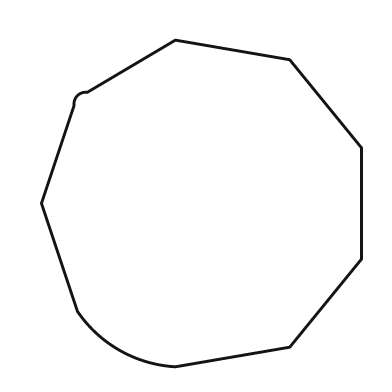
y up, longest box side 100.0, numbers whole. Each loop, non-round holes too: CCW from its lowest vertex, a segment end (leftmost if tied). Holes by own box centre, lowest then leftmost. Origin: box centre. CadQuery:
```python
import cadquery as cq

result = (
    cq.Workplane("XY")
    .moveTo(-8.0, -50.0)
    .lineTo(27.0, -44.0)
    .lineTo(49.0, -17.0)
    .lineTo(49.0, 17.0)
    .lineTo(27.0, 44.0)
    .lineTo(-8.0, 50.0)
    .lineTo(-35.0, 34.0)
    .threePointArc((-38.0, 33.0), (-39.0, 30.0))
    .lineTo(-49.0, 0.0)
    .lineTo(-38.0, -33.0)
    .threePointArc((-25.0, -45.0), (-8.0, -50.0))
    .close()
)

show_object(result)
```